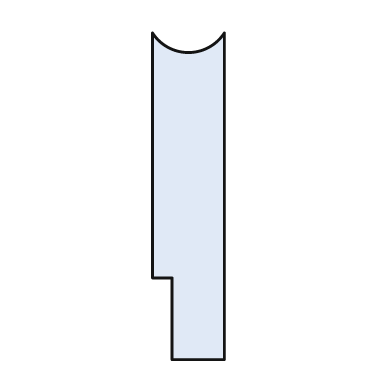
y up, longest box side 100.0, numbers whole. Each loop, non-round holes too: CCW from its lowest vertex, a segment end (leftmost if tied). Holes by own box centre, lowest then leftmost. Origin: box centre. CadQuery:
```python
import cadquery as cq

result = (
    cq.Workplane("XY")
    .moveTo(-5.0, -50.0)
    .lineTo(11.0, -50.0)
    .lineTo(11.0, 50.0)
    .threePointArc((0.0, 44.0), (-11.0, 50.0))
    .lineTo(-11.0, -25.0)
    .lineTo(-5.0, -25.0)
    .close()
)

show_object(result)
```